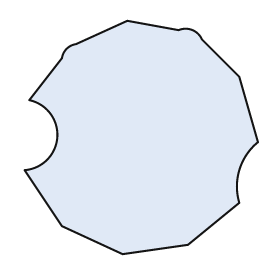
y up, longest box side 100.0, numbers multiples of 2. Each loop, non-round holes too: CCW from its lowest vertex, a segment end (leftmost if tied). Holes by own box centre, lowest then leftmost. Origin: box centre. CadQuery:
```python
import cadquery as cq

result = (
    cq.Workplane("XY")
    .moveTo(-8.0, -50.0)
    .lineTo(20.0, -46.0)
    .lineTo(42.0, -28.0)
    .threePointArc((42.0, -14.0), (50.0, -2.0))
    .lineTo(42.0, 26.0)
    .lineTo(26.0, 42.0)
    .threePointArc((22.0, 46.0), (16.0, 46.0))
    .lineTo(-6.0, 50.0)
    .lineTo(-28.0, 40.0)
    .threePointArc((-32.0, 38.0), (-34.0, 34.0))
    .lineTo(-48.0, 16.0)
    .threePointArc((-36.0, 0.0), (-50.0, -14.0))
    .lineTo(-34.0, -38.0)
    .close()
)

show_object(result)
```